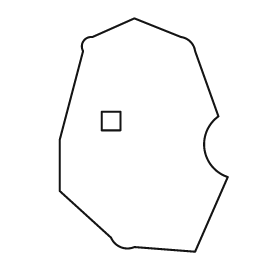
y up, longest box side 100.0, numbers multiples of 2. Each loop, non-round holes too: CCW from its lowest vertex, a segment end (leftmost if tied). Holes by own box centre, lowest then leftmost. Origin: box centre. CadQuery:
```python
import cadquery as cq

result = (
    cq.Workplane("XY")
    .moveTo(22.0, -50.0)
    .lineTo(36.0, -18.0)
    .threePointArc((26.0, -6.0), (32.0, 8.0))
    .lineTo(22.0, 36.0)
    .threePointArc((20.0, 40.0), (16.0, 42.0))
    .lineTo(-4.0, 50.0)
    .lineTo(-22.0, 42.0)
    .threePointArc((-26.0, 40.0), (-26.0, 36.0))
    .lineTo(-36.0, -2.0)
    .lineTo(-36.0, -24.0)
    .lineTo(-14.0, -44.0)
    .threePointArc((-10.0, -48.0), (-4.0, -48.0))
    .close()
    .moveTo(-18.0, 2.0)
    .lineTo(-10.0, 2.0)
    .lineTo(-10.0, 10.0)
    .lineTo(-18.0, 10.0)
    .close()
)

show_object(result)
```